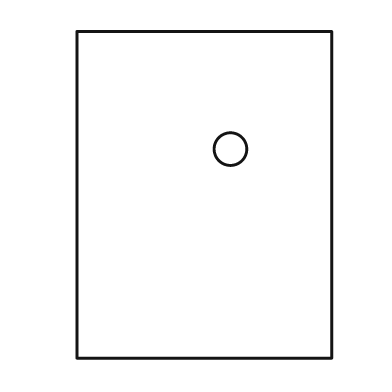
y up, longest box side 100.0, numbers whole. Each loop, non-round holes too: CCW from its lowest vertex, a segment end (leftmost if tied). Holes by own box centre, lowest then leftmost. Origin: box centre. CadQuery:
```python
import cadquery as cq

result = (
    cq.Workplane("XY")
    .moveTo(-39.0, -50.0)
    .lineTo(39.0, -50.0)
    .lineTo(39.0, 50.0)
    .lineTo(-39.0, 50.0)
    .close()
    .moveTo(8.0, 14.0)
    .circle(5.0)
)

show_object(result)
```